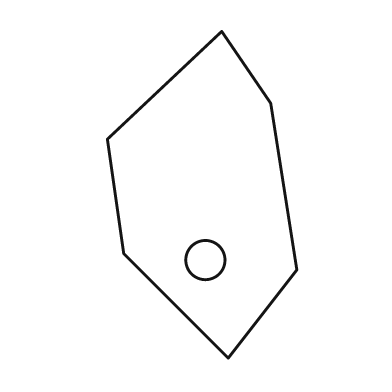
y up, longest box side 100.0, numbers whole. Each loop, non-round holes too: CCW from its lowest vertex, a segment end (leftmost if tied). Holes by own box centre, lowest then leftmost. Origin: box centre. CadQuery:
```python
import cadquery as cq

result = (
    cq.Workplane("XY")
    .moveTo(8.0, -50.0)
    .lineTo(29.0, -23.0)
    .lineTo(21.0, 28.0)
    .lineTo(6.0, 50.0)
    .lineTo(-29.0, 17.0)
    .lineTo(-24.0, -18.0)
    .close()
    .moveTo(1.0, -20.0)
    .circle(6.0)
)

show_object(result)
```